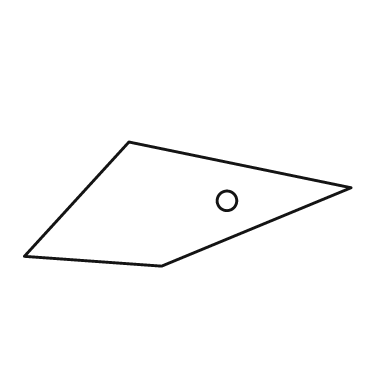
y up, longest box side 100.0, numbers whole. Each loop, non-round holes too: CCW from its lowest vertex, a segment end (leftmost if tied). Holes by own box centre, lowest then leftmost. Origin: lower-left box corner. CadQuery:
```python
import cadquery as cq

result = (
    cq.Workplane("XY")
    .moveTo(42.0, 0.0)
    .lineTo(100.0, 24.0)
    .lineTo(32.0, 38.0)
    .lineTo(0.0, 3.0)
    .close()
    .moveTo(62.0, 20.0)
    .circle(3.0)
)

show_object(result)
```